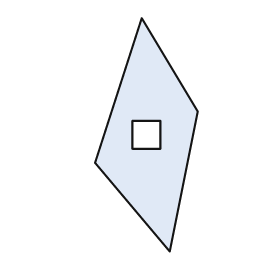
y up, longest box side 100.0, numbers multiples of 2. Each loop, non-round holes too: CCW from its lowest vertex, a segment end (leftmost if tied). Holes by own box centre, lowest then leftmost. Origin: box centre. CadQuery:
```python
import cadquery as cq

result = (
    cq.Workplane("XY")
    .moveTo(10.0, -50.0)
    .lineTo(22.0, 10.0)
    .lineTo(-2.0, 50.0)
    .lineTo(-22.0, -12.0)
    .close()
    .moveTo(-6.0, -6.0)
    .lineTo(6.0, -6.0)
    .lineTo(6.0, 6.0)
    .lineTo(-6.0, 6.0)
    .close()
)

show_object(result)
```